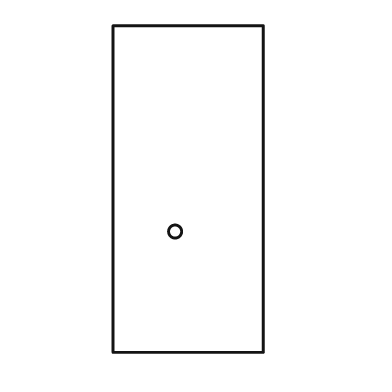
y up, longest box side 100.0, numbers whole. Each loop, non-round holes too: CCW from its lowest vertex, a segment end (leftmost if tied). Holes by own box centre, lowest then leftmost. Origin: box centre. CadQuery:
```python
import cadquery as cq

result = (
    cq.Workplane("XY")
    .moveTo(-23.0, -50.0)
    .lineTo(23.0, -50.0)
    .lineTo(23.0, 50.0)
    .lineTo(-23.0, 50.0)
    .close()
    .moveTo(-4.0, -13.0)
    .circle(2.0)
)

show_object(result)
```